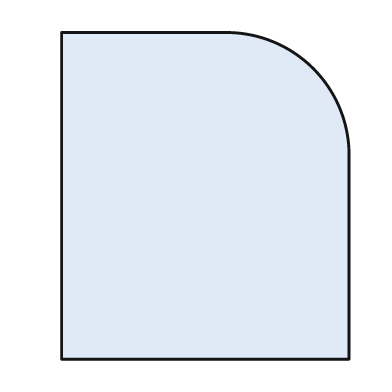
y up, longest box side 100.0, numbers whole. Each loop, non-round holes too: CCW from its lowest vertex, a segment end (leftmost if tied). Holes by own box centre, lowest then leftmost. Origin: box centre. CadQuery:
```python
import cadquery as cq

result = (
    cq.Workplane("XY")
    .moveTo(-44.0, -50.0)
    .lineTo(44.0, -50.0)
    .lineTo(44.0, 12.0)
    .threePointArc((33.0, 39.0), (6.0, 50.0))
    .lineTo(-44.0, 50.0)
    .close()
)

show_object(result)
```